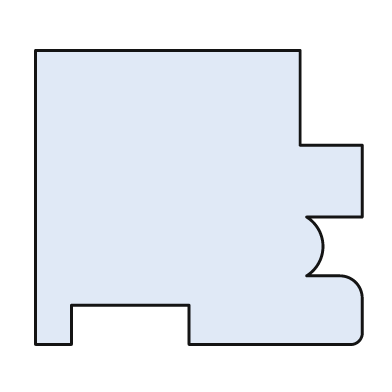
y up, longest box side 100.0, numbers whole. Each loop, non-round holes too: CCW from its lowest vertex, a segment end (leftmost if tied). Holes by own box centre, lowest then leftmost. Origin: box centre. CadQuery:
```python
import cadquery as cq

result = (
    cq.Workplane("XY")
    .moveTo(-50.0, -45.0)
    .lineTo(-39.0, -45.0)
    .lineTo(-39.0, -33.0)
    .lineTo(-3.0, -33.0)
    .lineTo(-3.0, -45.0)
    .lineTo(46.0, -45.0)
    .threePointArc((49.0, -44.0), (50.0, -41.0))
    .lineTo(50.0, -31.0)
    .threePointArc((48.0, -26.0), (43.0, -24.0))
    .lineTo(33.0, -24.0)
    .threePointArc((38.0, -15.0), (33.0, -6.0))
    .lineTo(50.0, -6.0)
    .lineTo(50.0, 16.0)
    .lineTo(31.0, 16.0)
    .lineTo(31.0, 45.0)
    .lineTo(-50.0, 45.0)
    .close()
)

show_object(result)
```